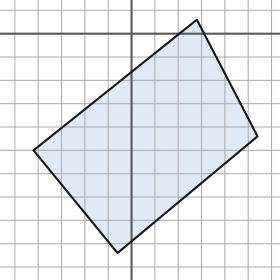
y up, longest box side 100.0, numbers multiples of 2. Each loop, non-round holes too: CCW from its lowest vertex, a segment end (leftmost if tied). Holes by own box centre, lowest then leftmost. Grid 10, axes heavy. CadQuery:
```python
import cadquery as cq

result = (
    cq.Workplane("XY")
    .moveTo(-6.0, -94.0)
    .lineTo(54.0, -44.0)
    .lineTo(28.0, 6.0)
    .lineTo(-42.0, -50.0)
    .close()
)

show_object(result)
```